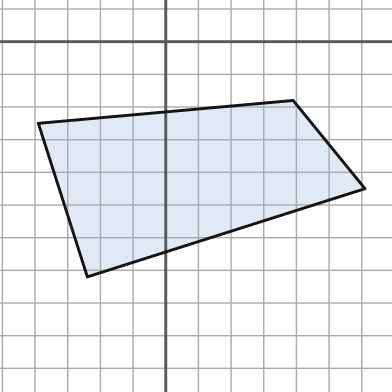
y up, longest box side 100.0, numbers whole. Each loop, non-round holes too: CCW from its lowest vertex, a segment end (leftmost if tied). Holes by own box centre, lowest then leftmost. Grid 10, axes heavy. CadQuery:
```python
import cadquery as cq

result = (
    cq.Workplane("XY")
    .moveTo(-24.0, -72.0)
    .lineTo(61.0, -45.0)
    .lineTo(39.0, -18.0)
    .lineTo(-39.0, -25.0)
    .close()
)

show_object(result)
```